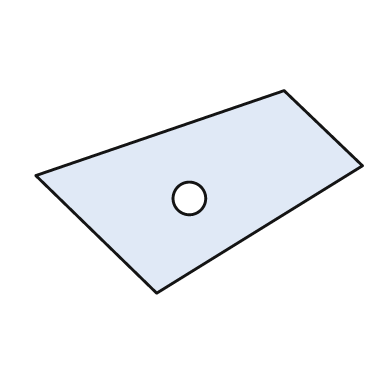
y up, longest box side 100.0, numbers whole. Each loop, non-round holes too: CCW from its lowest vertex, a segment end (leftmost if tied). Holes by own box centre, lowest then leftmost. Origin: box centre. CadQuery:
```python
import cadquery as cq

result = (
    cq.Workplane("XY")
    .moveTo(-13.0, -31.0)
    .lineTo(50.0, 8.0)
    .lineTo(26.0, 31.0)
    .lineTo(-50.0, 5.0)
    .close()
    .moveTo(-3.0, -2.0)
    .circle(5.0)
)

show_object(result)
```